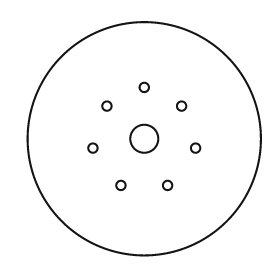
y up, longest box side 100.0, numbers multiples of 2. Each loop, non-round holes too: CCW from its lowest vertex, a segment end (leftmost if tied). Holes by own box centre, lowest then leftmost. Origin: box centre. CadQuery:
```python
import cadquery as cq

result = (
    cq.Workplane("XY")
    .moveTo(0.0, 0.0)
    .circle(50.0)
    .moveTo(-10.0, -20.0)
    .circle(2.0)
    .moveTo(10.0, -20.0)
    .circle(2.0)
    .moveTo(-22.0, -4.0)
    .circle(2.0)
    .moveTo(22.0, -4.0)
    .circle(2.0)
    .moveTo(0.0, 0.0)
    .circle(6.0)
    .moveTo(-16.0, 14.0)
    .circle(2.0)
    .moveTo(16.0, 14.0)
    .circle(2.0)
    .moveTo(0.0, 22.0)
    .circle(2.0)
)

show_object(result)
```